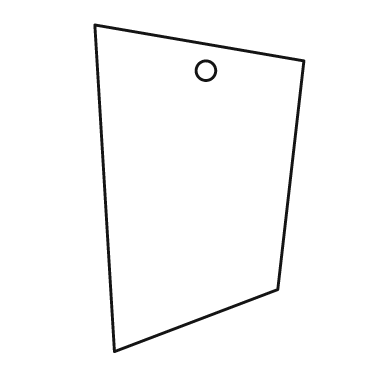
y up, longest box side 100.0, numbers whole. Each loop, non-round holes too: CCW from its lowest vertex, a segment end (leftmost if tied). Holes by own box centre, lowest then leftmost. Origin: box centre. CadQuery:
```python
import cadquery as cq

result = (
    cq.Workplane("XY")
    .moveTo(-26.0, -50.0)
    .lineTo(24.0, -31.0)
    .lineTo(32.0, 39.0)
    .lineTo(-32.0, 50.0)
    .close()
    .moveTo(2.0, 36.0)
    .circle(3.0)
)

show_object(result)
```